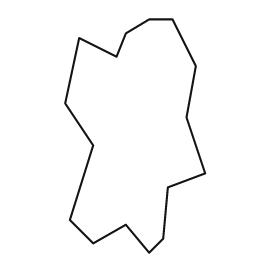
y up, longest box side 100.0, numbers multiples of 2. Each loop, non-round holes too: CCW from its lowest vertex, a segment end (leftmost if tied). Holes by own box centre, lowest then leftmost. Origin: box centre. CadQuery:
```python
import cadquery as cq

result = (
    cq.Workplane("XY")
    .moveTo(6.0, -50.0)
    .lineTo(12.0, -44.0)
    .lineTo(14.0, -22.0)
    .lineTo(30.0, -16.0)
    .lineTo(22.0, 8.0)
    .lineTo(26.0, 30.0)
    .lineTo(16.0, 50.0)
    .lineTo(6.0, 50.0)
    .lineTo(-4.0, 44.0)
    .lineTo(-8.0, 34.0)
    .lineTo(-24.0, 42.0)
    .lineTo(-30.0, 14.0)
    .lineTo(-18.0, -4.0)
    .lineTo(-28.0, -36.0)
    .lineTo(-18.0, -46.0)
    .lineTo(-4.0, -38.0)
    .close()
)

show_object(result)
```